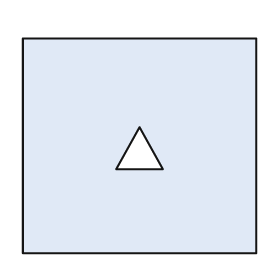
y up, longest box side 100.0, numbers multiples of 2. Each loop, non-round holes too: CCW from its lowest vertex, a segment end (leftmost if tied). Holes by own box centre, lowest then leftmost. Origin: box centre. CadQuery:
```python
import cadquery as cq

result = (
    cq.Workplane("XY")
    .moveTo(-50.0, -46.0)
    .lineTo(50.0, -46.0)
    .lineTo(50.0, 46.0)
    .lineTo(-50.0, 46.0)
    .close()
    .moveTo(-10.0, -10.0)
    .lineTo(10.0, -10.0)
    .lineTo(0.0, 8.0)
    .close()
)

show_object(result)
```